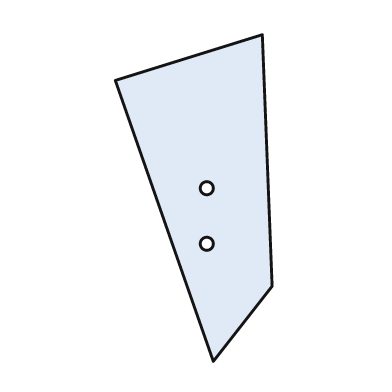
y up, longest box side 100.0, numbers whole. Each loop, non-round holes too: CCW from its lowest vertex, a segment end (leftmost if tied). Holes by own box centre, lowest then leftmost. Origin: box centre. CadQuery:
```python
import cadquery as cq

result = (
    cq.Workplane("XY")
    .moveTo(6.0, -50.0)
    .lineTo(24.0, -27.0)
    .lineTo(21.0, 50.0)
    .lineTo(-24.0, 36.0)
    .close()
    .moveTo(4.0, -14.0)
    .circle(2.0)
    .moveTo(4.0, 3.0)
    .circle(2.0)
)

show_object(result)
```